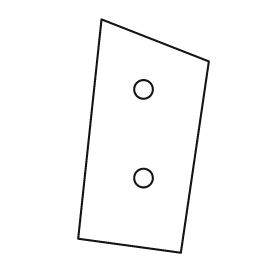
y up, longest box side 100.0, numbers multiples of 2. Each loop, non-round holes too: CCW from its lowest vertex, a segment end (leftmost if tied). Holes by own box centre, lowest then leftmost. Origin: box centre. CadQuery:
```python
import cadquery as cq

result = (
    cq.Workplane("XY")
    .moveTo(16.0, -50.0)
    .lineTo(28.0, 32.0)
    .lineTo(-18.0, 50.0)
    .lineTo(-28.0, -44.0)
    .close()
    .moveTo(0.0, -18.0)
    .circle(4.0)
    .moveTo(0.0, 20.0)
    .circle(4.0)
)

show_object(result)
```